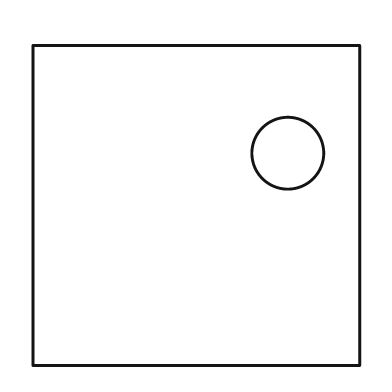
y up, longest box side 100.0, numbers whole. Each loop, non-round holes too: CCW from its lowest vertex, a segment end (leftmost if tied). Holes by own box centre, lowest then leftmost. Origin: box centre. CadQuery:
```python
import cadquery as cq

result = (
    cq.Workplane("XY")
    .moveTo(-50.0, -49.0)
    .lineTo(50.0, -49.0)
    .lineTo(50.0, 49.0)
    .lineTo(-50.0, 49.0)
    .close()
    .moveTo(28.0, 16.0)
    .circle(11.0)
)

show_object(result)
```